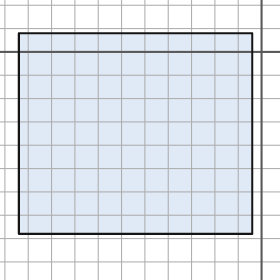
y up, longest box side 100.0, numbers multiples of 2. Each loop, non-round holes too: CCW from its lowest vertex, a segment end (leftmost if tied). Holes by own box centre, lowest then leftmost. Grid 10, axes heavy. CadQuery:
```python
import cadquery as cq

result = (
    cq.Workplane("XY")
    .moveTo(-104.0, -78.0)
    .lineTo(-4.0, -78.0)
    .lineTo(-4.0, 8.0)
    .lineTo(-104.0, 8.0)
    .close()
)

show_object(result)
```